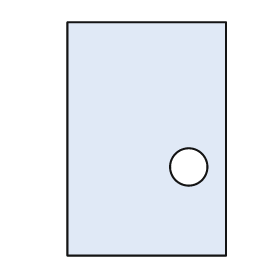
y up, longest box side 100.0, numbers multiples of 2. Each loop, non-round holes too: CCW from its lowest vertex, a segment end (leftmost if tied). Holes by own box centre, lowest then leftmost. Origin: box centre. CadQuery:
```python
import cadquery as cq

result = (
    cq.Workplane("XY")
    .moveTo(-34.0, -50.0)
    .lineTo(34.0, -50.0)
    .lineTo(34.0, 50.0)
    .lineTo(-34.0, 50.0)
    .close()
    .moveTo(18.0, -12.0)
    .circle(8.0)
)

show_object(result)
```